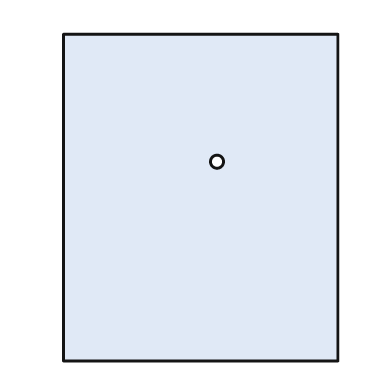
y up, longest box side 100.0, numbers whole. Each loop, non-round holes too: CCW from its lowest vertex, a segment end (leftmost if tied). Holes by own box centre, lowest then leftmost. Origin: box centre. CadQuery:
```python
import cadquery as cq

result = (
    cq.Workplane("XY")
    .moveTo(-42.0, -50.0)
    .lineTo(42.0, -50.0)
    .lineTo(42.0, 50.0)
    .lineTo(-42.0, 50.0)
    .close()
    .moveTo(5.0, 11.0)
    .circle(2.0)
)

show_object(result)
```